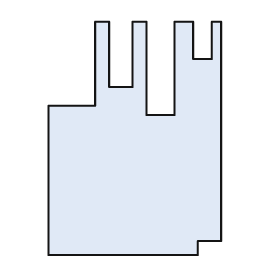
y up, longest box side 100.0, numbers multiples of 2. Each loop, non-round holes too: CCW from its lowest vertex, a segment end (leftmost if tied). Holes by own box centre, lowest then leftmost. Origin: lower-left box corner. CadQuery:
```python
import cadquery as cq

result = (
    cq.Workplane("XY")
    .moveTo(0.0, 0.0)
    .lineTo(64.0, 0.0)
    .lineTo(64.0, 6.0)
    .lineTo(74.0, 6.0)
    .lineTo(74.0, 100.0)
    .lineTo(70.0, 100.0)
    .lineTo(70.0, 84.0)
    .lineTo(62.0, 84.0)
    .lineTo(62.0, 100.0)
    .lineTo(54.0, 100.0)
    .lineTo(54.0, 60.0)
    .lineTo(42.0, 60.0)
    .lineTo(42.0, 100.0)
    .lineTo(36.0, 100.0)
    .lineTo(36.0, 72.0)
    .lineTo(26.0, 72.0)
    .lineTo(26.0, 100.0)
    .lineTo(20.0, 100.0)
    .lineTo(20.0, 64.0)
    .lineTo(0.0, 64.0)
    .close()
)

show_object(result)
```